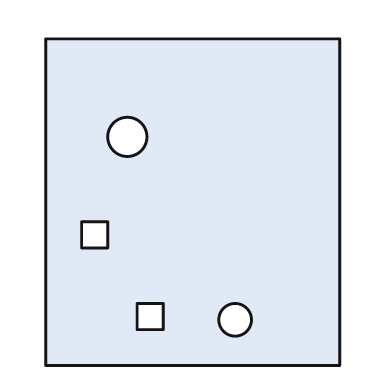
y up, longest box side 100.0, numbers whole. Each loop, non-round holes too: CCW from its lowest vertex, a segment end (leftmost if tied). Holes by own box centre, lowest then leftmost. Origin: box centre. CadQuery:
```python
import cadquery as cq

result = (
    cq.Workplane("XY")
    .moveTo(-45.0, -50.0)
    .lineTo(45.0, -50.0)
    .lineTo(45.0, 50.0)
    .lineTo(-45.0, 50.0)
    .close()
    .moveTo(13.0, -36.0)
    .circle(5.0)
    .moveTo(-17.0, -39.0)
    .lineTo(-9.0, -39.0)
    .lineTo(-9.0, -31.0)
    .lineTo(-17.0, -31.0)
    .close()
    .moveTo(-34.0, -14.0)
    .lineTo(-26.0, -14.0)
    .lineTo(-26.0, -6.0)
    .lineTo(-34.0, -6.0)
    .close()
    .moveTo(-20.0, 20.0)
    .circle(6.0)
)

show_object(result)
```